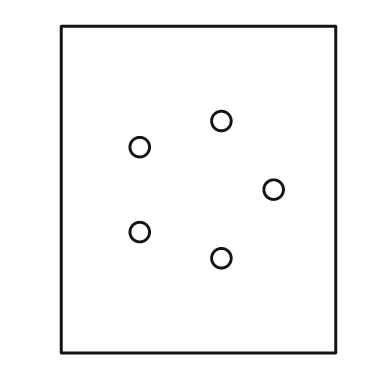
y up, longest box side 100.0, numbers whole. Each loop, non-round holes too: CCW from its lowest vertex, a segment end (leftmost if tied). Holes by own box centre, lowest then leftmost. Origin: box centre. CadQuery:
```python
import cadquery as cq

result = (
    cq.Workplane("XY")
    .moveTo(-42.0, -50.0)
    .lineTo(42.0, -50.0)
    .lineTo(42.0, 50.0)
    .lineTo(-42.0, 50.0)
    .close()
    .moveTo(7.0, -21.0)
    .circle(3.0)
    .moveTo(-18.0, -13.0)
    .circle(3.0)
    .moveTo(23.0, 0.0)
    .circle(3.0)
    .moveTo(-18.0, 13.0)
    .circle(3.0)
    .moveTo(7.0, 21.0)
    .circle(3.0)
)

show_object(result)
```